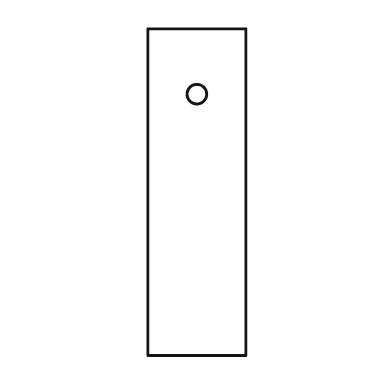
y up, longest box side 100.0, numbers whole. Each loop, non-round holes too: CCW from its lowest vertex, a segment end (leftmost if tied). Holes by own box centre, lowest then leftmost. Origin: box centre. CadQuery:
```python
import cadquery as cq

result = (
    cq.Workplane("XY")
    .moveTo(-15.0, -50.0)
    .lineTo(15.0, -50.0)
    .lineTo(15.0, 50.0)
    .lineTo(-15.0, 50.0)
    .close()
    .moveTo(0.0, 30.0)
    .circle(3.0)
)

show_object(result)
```